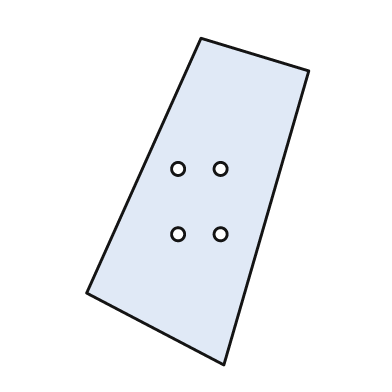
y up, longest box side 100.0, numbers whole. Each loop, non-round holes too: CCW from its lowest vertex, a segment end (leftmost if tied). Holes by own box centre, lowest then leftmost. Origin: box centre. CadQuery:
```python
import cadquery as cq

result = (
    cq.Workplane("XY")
    .moveTo(8.0, -50.0)
    .lineTo(34.0, 40.0)
    .lineTo(1.0, 50.0)
    .lineTo(-34.0, -28.0)
    .close()
    .moveTo(-6.0, -10.0)
    .circle(2.0)
    .moveTo(7.0, -10.0)
    .circle(2.0)
    .moveTo(-6.0, 10.0)
    .circle(2.0)
    .moveTo(7.0, 10.0)
    .circle(2.0)
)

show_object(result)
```